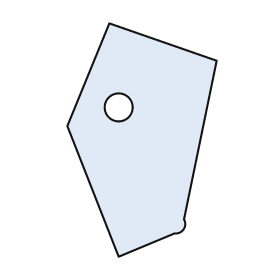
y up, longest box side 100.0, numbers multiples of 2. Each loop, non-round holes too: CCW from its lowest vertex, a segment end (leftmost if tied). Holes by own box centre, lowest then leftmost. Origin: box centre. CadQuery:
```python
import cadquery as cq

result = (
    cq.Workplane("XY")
    .moveTo(-10.0, -50.0)
    .lineTo(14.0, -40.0)
    .threePointArc((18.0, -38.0), (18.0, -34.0))
    .lineTo(32.0, 34.0)
    .lineTo(-14.0, 50.0)
    .lineTo(-32.0, 6.0)
    .close()
    .moveTo(-10.0, 14.0)
    .circle(6.0)
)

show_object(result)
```